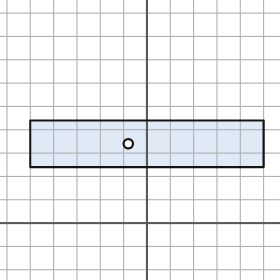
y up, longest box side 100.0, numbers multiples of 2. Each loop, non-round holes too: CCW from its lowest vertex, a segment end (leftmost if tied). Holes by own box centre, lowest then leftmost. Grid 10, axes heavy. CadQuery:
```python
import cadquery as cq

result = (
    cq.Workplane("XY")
    .moveTo(-50.0, 24.0)
    .lineTo(50.0, 24.0)
    .lineTo(50.0, 44.0)
    .lineTo(-50.0, 44.0)
    .close()
    .moveTo(-8.0, 34.0)
    .circle(2.0)
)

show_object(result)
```